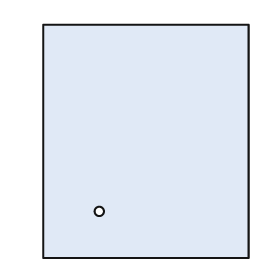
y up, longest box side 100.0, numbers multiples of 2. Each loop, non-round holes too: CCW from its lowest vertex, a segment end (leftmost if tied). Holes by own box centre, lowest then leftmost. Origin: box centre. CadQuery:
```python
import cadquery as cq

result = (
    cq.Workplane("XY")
    .moveTo(-44.0, -50.0)
    .lineTo(44.0, -50.0)
    .lineTo(44.0, 50.0)
    .lineTo(-44.0, 50.0)
    .close()
    .moveTo(-20.0, -30.0)
    .circle(2.0)
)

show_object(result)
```